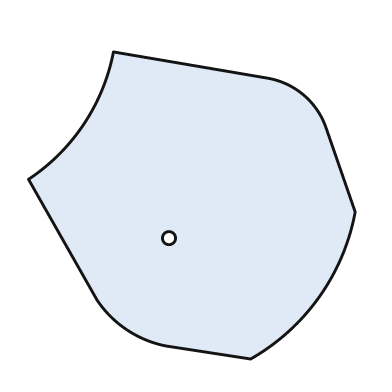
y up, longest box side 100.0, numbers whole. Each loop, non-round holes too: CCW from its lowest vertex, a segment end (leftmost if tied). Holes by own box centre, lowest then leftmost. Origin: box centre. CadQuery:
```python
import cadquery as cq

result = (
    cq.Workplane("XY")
    .moveTo(18.0, -47.0)
    .threePointArc((39.0, -28.0), (50.0, -2.0))
    .lineTo(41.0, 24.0)
    .threePointArc((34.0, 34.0), (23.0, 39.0))
    .lineTo(-24.0, 47.0)
    .threePointArc((-33.0, 25.0), (-50.0, 8.0))
    .lineTo(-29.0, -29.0)
    .threePointArc((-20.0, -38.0), (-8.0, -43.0))
    .close()
    .moveTo(-7.0, -10.0)
    .circle(2.0)
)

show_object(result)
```